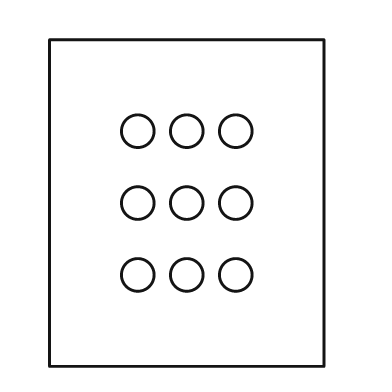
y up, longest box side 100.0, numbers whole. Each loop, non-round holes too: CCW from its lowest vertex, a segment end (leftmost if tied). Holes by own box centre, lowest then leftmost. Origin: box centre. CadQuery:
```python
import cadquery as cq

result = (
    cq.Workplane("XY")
    .moveTo(-42.0, -50.0)
    .lineTo(42.0, -50.0)
    .lineTo(42.0, 50.0)
    .lineTo(-42.0, 50.0)
    .close()
    .moveTo(-15.0, -22.0)
    .circle(5.0)
    .moveTo(0.0, -22.0)
    .circle(5.0)
    .moveTo(15.0, -22.0)
    .circle(5.0)
    .moveTo(-15.0, 0.0)
    .circle(5.0)
    .moveTo(0.0, 0.0)
    .circle(5.0)
    .moveTo(15.0, 0.0)
    .circle(5.0)
    .moveTo(-15.0, 22.0)
    .circle(5.0)
    .moveTo(0.0, 22.0)
    .circle(5.0)
    .moveTo(15.0, 22.0)
    .circle(5.0)
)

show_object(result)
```